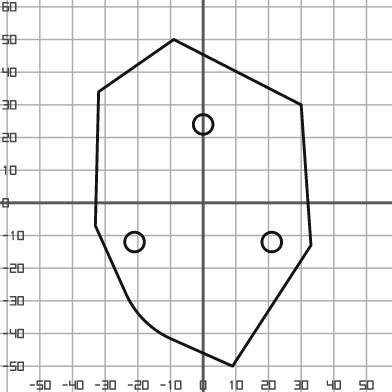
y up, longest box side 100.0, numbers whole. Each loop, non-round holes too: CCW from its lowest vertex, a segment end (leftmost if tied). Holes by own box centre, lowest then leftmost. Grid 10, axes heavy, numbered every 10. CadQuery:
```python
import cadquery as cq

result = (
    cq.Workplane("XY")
    .moveTo(9.0, -50.0)
    .lineTo(33.0, -13.0)
    .lineTo(30.0, 30.0)
    .lineTo(-9.0, 50.0)
    .lineTo(-32.0, 34.0)
    .lineTo(-33.0, -7.0)
    .lineTo(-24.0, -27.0)
    .threePointArc((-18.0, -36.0), (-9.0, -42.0))
    .close()
    .moveTo(-21.0, -12.0)
    .circle(3.0)
    .moveTo(21.0, -12.0)
    .circle(3.0)
    .moveTo(0.0, 24.0)
    .circle(3.0)
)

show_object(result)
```